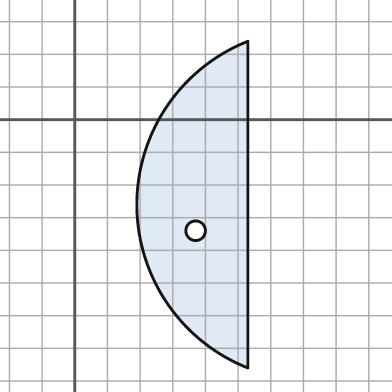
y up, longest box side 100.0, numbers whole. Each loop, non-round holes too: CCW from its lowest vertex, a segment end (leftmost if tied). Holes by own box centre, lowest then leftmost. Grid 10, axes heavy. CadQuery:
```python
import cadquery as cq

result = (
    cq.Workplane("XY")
    .moveTo(53.0, -76.0)
    .lineTo(53.0, 24.0)
    .threePointArc((19.0, -26.0), (53.0, -76.0))
    .close()
    .moveTo(37.0, -34.0)
    .circle(3.0)
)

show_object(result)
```